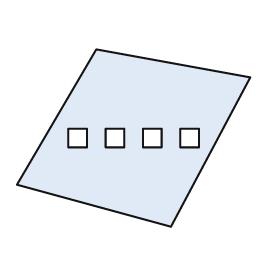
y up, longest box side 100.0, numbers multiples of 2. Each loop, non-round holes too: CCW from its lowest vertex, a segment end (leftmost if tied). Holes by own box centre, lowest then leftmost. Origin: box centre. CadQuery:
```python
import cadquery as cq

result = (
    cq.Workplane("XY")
    .moveTo(16.0, -38.0)
    .lineTo(50.0, 26.0)
    .lineTo(-16.0, 38.0)
    .lineTo(-50.0, -20.0)
    .close()
    .moveTo(-28.0, -4.0)
    .lineTo(-20.0, -4.0)
    .lineTo(-20.0, 4.0)
    .lineTo(-28.0, 4.0)
    .close()
    .moveTo(-12.0, -4.0)
    .lineTo(-4.0, -4.0)
    .lineTo(-4.0, 4.0)
    .lineTo(-12.0, 4.0)
    .close()
    .moveTo(4.0, -4.0)
    .lineTo(12.0, -4.0)
    .lineTo(12.0, 4.0)
    .lineTo(4.0, 4.0)
    .close()
    .moveTo(20.0, -4.0)
    .lineTo(28.0, -4.0)
    .lineTo(28.0, 4.0)
    .lineTo(20.0, 4.0)
    .close()
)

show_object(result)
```